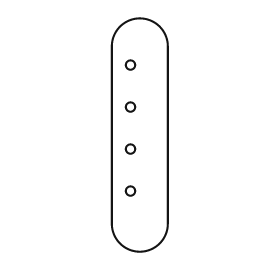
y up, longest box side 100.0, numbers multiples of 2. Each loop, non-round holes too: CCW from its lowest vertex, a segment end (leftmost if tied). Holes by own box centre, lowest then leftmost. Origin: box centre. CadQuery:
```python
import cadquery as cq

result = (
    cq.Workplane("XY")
    .moveTo(-12.0, -38.0)
    .threePointArc((0.0, -50.0), (12.0, -38.0))
    .lineTo(12.0, 38.0)
    .threePointArc((0.0, 50.0), (-12.0, 38.0))
    .close()
    .moveTo(-4.0, -24.0)
    .circle(2.0)
    .moveTo(-4.0, -6.0)
    .circle(2.0)
    .moveTo(-4.0, 12.0)
    .circle(2.0)
    .moveTo(-4.0, 30.0)
    .circle(2.0)
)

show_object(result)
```